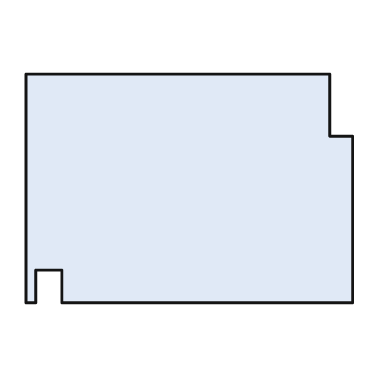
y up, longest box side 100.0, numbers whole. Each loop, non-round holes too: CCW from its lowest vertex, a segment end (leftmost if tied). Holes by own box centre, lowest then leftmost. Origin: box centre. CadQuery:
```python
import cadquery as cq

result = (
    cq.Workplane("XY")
    .moveTo(-50.0, -35.0)
    .lineTo(-47.0, -35.0)
    .lineTo(-47.0, -25.0)
    .lineTo(-39.0, -25.0)
    .lineTo(-39.0, -35.0)
    .lineTo(50.0, -35.0)
    .lineTo(50.0, 16.0)
    .lineTo(43.0, 16.0)
    .lineTo(43.0, 35.0)
    .lineTo(-50.0, 35.0)
    .close()
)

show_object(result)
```